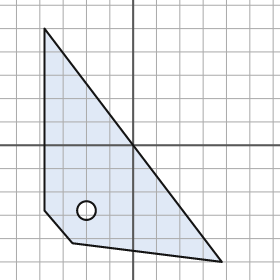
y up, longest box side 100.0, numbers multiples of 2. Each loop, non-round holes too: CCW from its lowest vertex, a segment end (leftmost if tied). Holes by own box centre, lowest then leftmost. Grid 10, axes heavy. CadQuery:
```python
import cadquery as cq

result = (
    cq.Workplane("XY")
    .moveTo(38.0, -50.0)
    .lineTo(-38.0, 50.0)
    .lineTo(-38.0, -28.0)
    .lineTo(-26.0, -42.0)
    .close()
    .moveTo(-20.0, -28.0)
    .circle(4.0)
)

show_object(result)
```